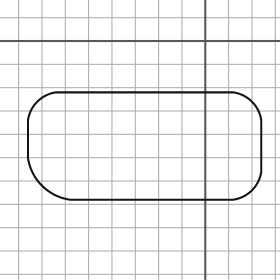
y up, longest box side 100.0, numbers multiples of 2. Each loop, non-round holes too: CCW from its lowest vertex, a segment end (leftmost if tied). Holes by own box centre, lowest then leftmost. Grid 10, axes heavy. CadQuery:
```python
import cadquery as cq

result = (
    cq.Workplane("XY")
    .moveTo(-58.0, -68.0)
    .lineTo(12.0, -68.0)
    .threePointArc((20.0, -64.0), (24.0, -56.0))
    .lineTo(24.0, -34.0)
    .threePointArc((20.0, -26.0), (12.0, -22.0))
    .lineTo(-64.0, -22.0)
    .threePointArc((-72.0, -26.0), (-76.0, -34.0))
    .lineTo(-76.0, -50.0)
    .threePointArc((-70.0, -62.0), (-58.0, -68.0))
    .close()
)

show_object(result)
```